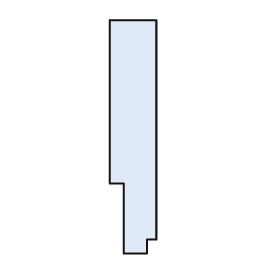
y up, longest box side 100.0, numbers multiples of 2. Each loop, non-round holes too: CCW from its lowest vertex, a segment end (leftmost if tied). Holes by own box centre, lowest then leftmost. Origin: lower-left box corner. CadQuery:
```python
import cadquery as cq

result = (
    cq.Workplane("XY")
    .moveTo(6.0, 0.0)
    .lineTo(16.0, 0.0)
    .lineTo(16.0, 6.0)
    .lineTo(20.0, 6.0)
    .lineTo(20.0, 100.0)
    .lineTo(0.0, 100.0)
    .lineTo(0.0, 30.0)
    .lineTo(6.0, 30.0)
    .close()
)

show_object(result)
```